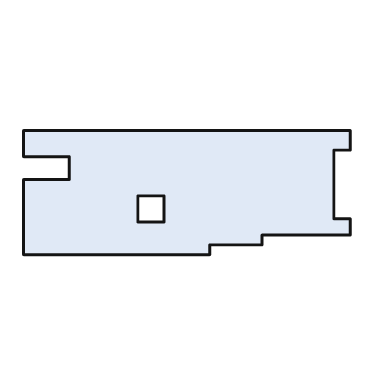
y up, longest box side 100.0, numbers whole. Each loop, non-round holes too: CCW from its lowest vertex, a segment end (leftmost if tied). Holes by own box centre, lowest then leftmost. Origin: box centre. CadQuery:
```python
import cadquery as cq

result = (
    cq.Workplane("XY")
    .moveTo(-50.0, -19.0)
    .lineTo(7.0, -19.0)
    .lineTo(7.0, -16.0)
    .lineTo(23.0, -16.0)
    .lineTo(23.0, -13.0)
    .lineTo(50.0, -13.0)
    .lineTo(50.0, -8.0)
    .lineTo(45.0, -8.0)
    .lineTo(45.0, 13.0)
    .lineTo(50.0, 13.0)
    .lineTo(50.0, 19.0)
    .lineTo(-50.0, 19.0)
    .lineTo(-50.0, 11.0)
    .lineTo(-36.0, 11.0)
    .lineTo(-36.0, 4.0)
    .lineTo(-50.0, 4.0)
    .close()
    .moveTo(-15.0, -9.0)
    .lineTo(-7.0, -9.0)
    .lineTo(-7.0, -1.0)
    .lineTo(-15.0, -1.0)
    .close()
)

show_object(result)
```